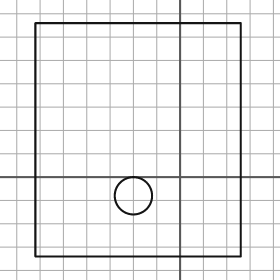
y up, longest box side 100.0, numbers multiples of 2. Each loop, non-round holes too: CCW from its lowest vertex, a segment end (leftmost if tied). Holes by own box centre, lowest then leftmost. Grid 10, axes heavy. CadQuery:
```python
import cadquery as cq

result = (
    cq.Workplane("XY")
    .moveTo(-62.0, -34.0)
    .lineTo(26.0, -34.0)
    .lineTo(26.0, 66.0)
    .lineTo(-62.0, 66.0)
    .close()
    .moveTo(-20.0, -8.0)
    .circle(8.0)
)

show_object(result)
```